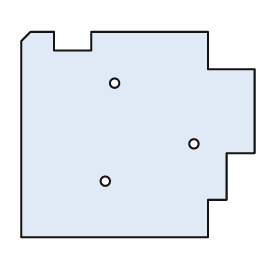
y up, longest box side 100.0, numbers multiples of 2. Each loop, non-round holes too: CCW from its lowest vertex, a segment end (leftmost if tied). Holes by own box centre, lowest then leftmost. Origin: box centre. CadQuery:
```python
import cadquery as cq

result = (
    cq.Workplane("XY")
    .moveTo(-50.0, -44.0)
    .lineTo(30.0, -44.0)
    .lineTo(30.0, -28.0)
    .lineTo(38.0, -28.0)
    .lineTo(38.0, -8.0)
    .lineTo(50.0, -8.0)
    .lineTo(50.0, 28.0)
    .lineTo(30.0, 28.0)
    .lineTo(30.0, 44.0)
    .lineTo(-20.0, 44.0)
    .lineTo(-20.0, 36.0)
    .lineTo(-36.0, 36.0)
    .lineTo(-36.0, 44.0)
    .lineTo(-46.0, 44.0)
    .lineTo(-50.0, 40.0)
    .close()
    .moveTo(-14.0, -20.0)
    .circle(2.0)
    .moveTo(24.0, -4.0)
    .circle(2.0)
    .moveTo(-10.0, 22.0)
    .circle(2.0)
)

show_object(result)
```